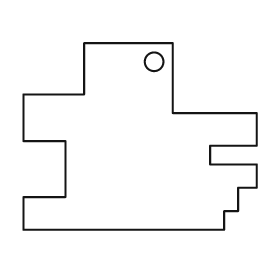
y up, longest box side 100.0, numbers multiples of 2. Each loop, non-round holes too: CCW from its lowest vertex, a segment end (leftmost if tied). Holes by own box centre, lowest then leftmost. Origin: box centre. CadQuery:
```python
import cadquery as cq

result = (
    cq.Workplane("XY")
    .moveTo(-50.0, -40.0)
    .lineTo(36.0, -40.0)
    .lineTo(36.0, -32.0)
    .lineTo(42.0, -32.0)
    .lineTo(42.0, -22.0)
    .lineTo(50.0, -22.0)
    .lineTo(50.0, -12.0)
    .lineTo(30.0, -12.0)
    .lineTo(30.0, -4.0)
    .lineTo(50.0, -4.0)
    .lineTo(50.0, 10.0)
    .lineTo(14.0, 10.0)
    .lineTo(14.0, 40.0)
    .lineTo(-24.0, 40.0)
    .lineTo(-24.0, 18.0)
    .lineTo(-50.0, 18.0)
    .lineTo(-50.0, -2.0)
    .lineTo(-32.0, -2.0)
    .lineTo(-32.0, -26.0)
    .lineTo(-50.0, -26.0)
    .close()
    .moveTo(6.0, 32.0)
    .circle(4.0)
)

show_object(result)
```